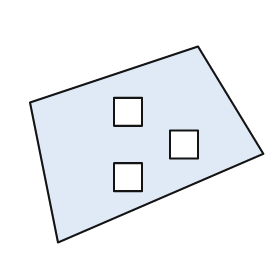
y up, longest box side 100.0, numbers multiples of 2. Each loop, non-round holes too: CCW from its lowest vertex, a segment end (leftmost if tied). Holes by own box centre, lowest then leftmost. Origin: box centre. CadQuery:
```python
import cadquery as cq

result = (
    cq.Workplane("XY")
    .moveTo(-38.0, -42.0)
    .lineTo(50.0, -4.0)
    .lineTo(22.0, 42.0)
    .lineTo(-50.0, 18.0)
    .close()
    .moveTo(-14.0, -20.0)
    .lineTo(-2.0, -20.0)
    .lineTo(-2.0, -8.0)
    .lineTo(-14.0, -8.0)
    .close()
    .moveTo(10.0, -6.0)
    .lineTo(22.0, -6.0)
    .lineTo(22.0, 6.0)
    .lineTo(10.0, 6.0)
    .close()
    .moveTo(-14.0, 8.0)
    .lineTo(-2.0, 8.0)
    .lineTo(-2.0, 20.0)
    .lineTo(-14.0, 20.0)
    .close()
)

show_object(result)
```